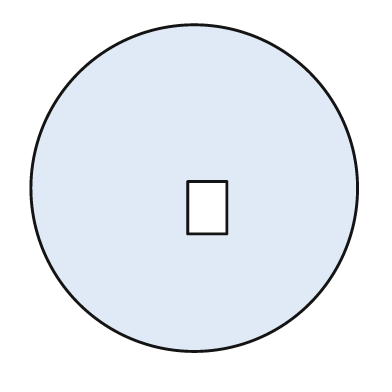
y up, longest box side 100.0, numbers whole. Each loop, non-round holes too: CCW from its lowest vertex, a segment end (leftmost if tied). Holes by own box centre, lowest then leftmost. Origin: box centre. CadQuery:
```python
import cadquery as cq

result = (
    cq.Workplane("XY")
    .moveTo(0.0, 0.0)
    .circle(50.0)
    .moveTo(-2.0, -14.0)
    .lineTo(10.0, -14.0)
    .lineTo(10.0, 2.0)
    .lineTo(-2.0, 2.0)
    .close()
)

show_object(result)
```